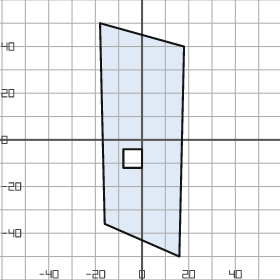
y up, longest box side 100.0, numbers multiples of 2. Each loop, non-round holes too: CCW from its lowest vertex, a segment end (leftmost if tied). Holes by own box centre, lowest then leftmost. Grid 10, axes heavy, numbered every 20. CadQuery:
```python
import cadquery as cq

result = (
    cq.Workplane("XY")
    .moveTo(16.0, -50.0)
    .lineTo(18.0, 40.0)
    .lineTo(-18.0, 50.0)
    .lineTo(-16.0, -36.0)
    .close()
    .moveTo(-8.0, -12.0)
    .lineTo(0.0, -12.0)
    .lineTo(0.0, -4.0)
    .lineTo(-8.0, -4.0)
    .close()
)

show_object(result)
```